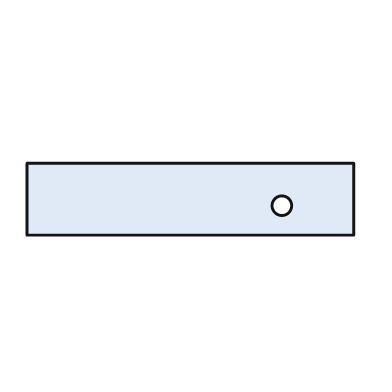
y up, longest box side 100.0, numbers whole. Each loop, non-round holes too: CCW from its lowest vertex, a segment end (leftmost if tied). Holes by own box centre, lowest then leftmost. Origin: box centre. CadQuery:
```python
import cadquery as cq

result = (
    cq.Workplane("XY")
    .moveTo(-50.0, -11.0)
    .lineTo(50.0, -11.0)
    .lineTo(50.0, 11.0)
    .lineTo(-50.0, 11.0)
    .close()
    .moveTo(28.0, -2.0)
    .circle(3.0)
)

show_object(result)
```